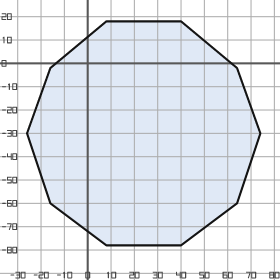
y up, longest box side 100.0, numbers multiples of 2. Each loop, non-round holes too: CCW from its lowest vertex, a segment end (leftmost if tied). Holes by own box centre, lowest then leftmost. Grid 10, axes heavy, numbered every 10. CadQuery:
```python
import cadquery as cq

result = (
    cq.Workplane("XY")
    .moveTo(8.0, -78.0)
    .lineTo(40.0, -78.0)
    .lineTo(64.0, -60.0)
    .lineTo(74.0, -30.0)
    .lineTo(64.0, -2.0)
    .lineTo(40.0, 18.0)
    .lineTo(8.0, 18.0)
    .lineTo(-16.0, -2.0)
    .lineTo(-26.0, -30.0)
    .lineTo(-16.0, -60.0)
    .close()
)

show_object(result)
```